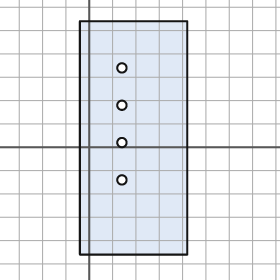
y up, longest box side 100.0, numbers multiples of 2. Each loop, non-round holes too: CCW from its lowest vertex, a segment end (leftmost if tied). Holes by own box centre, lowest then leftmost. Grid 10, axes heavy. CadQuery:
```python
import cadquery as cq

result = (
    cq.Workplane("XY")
    .moveTo(-4.0, -46.0)
    .lineTo(42.0, -46.0)
    .lineTo(42.0, 54.0)
    .lineTo(-4.0, 54.0)
    .close()
    .moveTo(14.0, -14.0)
    .circle(2.0)
    .moveTo(14.0, 2.0)
    .circle(2.0)
    .moveTo(14.0, 18.0)
    .circle(2.0)
    .moveTo(14.0, 34.0)
    .circle(2.0)
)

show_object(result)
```